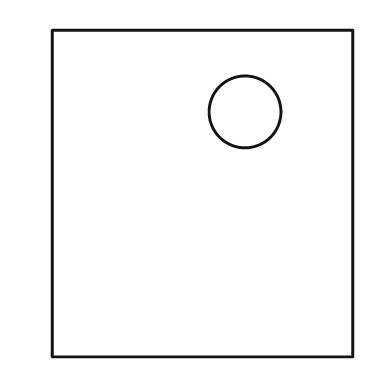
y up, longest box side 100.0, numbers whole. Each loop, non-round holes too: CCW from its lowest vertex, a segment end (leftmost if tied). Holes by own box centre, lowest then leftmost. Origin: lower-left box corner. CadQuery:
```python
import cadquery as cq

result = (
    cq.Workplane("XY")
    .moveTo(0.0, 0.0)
    .lineTo(92.0, 0.0)
    .lineTo(92.0, 100.0)
    .lineTo(0.0, 100.0)
    .close()
    .moveTo(59.0, 75.0)
    .circle(11.0)
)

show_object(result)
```